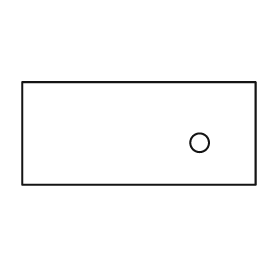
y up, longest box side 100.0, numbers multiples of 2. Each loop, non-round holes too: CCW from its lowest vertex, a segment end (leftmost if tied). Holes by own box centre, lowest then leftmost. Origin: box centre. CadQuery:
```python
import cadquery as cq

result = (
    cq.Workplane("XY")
    .moveTo(-50.0, -22.0)
    .lineTo(50.0, -22.0)
    .lineTo(50.0, 22.0)
    .lineTo(-50.0, 22.0)
    .close()
    .moveTo(26.0, -4.0)
    .circle(4.0)
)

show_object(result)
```